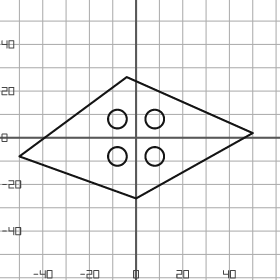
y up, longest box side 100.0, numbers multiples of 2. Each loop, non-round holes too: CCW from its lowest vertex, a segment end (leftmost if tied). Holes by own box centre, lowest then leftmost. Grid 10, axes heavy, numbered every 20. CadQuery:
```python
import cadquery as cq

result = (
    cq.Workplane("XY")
    .moveTo(0.0, -26.0)
    .lineTo(50.0, 2.0)
    .lineTo(-4.0, 26.0)
    .lineTo(-50.0, -8.0)
    .close()
    .moveTo(-8.0, -8.0)
    .circle(4.0)
    .moveTo(8.0, -8.0)
    .circle(4.0)
    .moveTo(-8.0, 8.0)
    .circle(4.0)
    .moveTo(8.0, 8.0)
    .circle(4.0)
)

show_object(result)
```